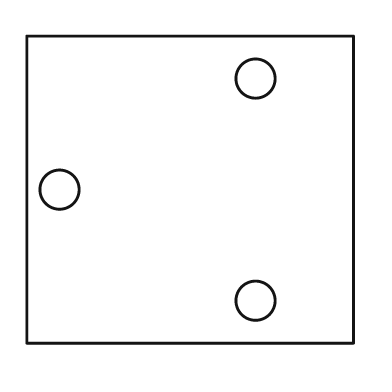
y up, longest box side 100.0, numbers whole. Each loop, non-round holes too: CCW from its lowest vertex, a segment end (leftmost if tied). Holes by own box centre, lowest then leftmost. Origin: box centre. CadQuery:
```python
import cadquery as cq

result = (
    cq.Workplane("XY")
    .moveTo(-50.0, -47.0)
    .lineTo(50.0, -47.0)
    .lineTo(50.0, 47.0)
    .lineTo(-50.0, 47.0)
    .close()
    .moveTo(20.0, -34.0)
    .circle(6.0)
    .moveTo(-40.0, 0.0)
    .circle(6.0)
    .moveTo(20.0, 34.0)
    .circle(6.0)
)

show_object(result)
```